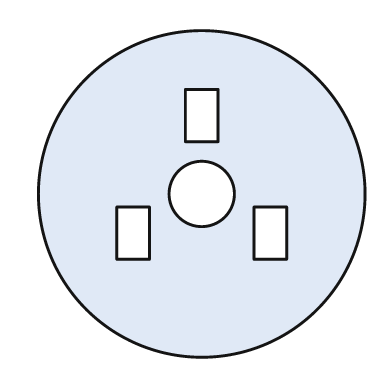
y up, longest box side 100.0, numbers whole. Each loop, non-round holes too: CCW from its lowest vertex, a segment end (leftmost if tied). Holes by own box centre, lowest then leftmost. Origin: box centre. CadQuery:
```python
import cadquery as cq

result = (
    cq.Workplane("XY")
    .moveTo(0.0, 0.0)
    .circle(50.0)
    .moveTo(-26.0, -20.0)
    .lineTo(-16.0, -20.0)
    .lineTo(-16.0, -4.0)
    .lineTo(-26.0, -4.0)
    .close()
    .moveTo(16.0, -20.0)
    .lineTo(26.0, -20.0)
    .lineTo(26.0, -4.0)
    .lineTo(16.0, -4.0)
    .close()
    .moveTo(0.0, 0.0)
    .circle(10.0)
    .moveTo(-5.0, 16.0)
    .lineTo(5.0, 16.0)
    .lineTo(5.0, 32.0)
    .lineTo(-5.0, 32.0)
    .close()
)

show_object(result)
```